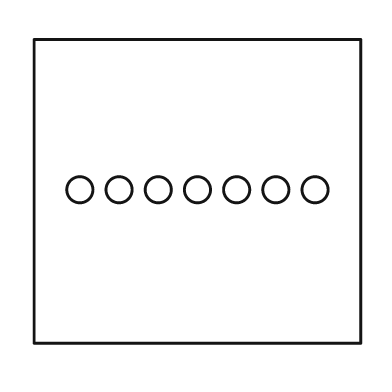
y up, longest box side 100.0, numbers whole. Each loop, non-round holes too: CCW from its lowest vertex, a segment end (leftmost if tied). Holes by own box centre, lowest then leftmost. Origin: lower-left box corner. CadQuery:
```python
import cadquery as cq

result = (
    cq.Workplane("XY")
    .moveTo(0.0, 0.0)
    .lineTo(100.0, 0.0)
    .lineTo(100.0, 93.0)
    .lineTo(0.0, 93.0)
    .close()
    .moveTo(14.0, 47.0)
    .circle(4.0)
    .moveTo(26.0, 47.0)
    .circle(4.0)
    .moveTo(38.0, 47.0)
    .circle(4.0)
    .moveTo(50.0, 47.0)
    .circle(4.0)
    .moveTo(62.0, 47.0)
    .circle(4.0)
    .moveTo(74.0, 47.0)
    .circle(4.0)
    .moveTo(86.0, 47.0)
    .circle(4.0)
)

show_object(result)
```